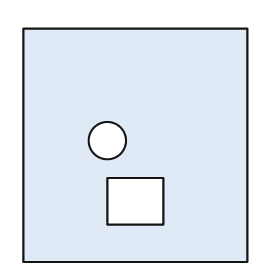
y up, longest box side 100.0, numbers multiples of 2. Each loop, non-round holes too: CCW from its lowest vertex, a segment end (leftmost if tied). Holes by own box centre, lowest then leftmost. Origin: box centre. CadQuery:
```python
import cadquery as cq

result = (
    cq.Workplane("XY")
    .moveTo(-48.0, -50.0)
    .lineTo(48.0, -50.0)
    .lineTo(48.0, 50.0)
    .lineTo(-48.0, 50.0)
    .close()
    .moveTo(-12.0, -34.0)
    .lineTo(12.0, -34.0)
    .lineTo(12.0, -14.0)
    .lineTo(-12.0, -14.0)
    .close()
    .moveTo(-12.0, 2.0)
    .circle(8.0)
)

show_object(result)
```